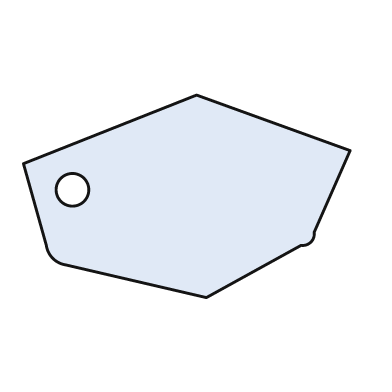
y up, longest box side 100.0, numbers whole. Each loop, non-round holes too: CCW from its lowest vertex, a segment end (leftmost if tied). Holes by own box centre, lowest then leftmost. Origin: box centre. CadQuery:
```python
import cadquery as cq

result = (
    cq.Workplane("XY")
    .moveTo(6.0, -31.0)
    .lineTo(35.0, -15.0)
    .threePointArc((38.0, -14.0), (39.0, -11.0))
    .lineTo(50.0, 14.0)
    .lineTo(3.0, 31.0)
    .lineTo(-50.0, 10.0)
    .lineTo(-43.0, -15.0)
    .threePointArc((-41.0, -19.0), (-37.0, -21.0))
    .close()
    .moveTo(-35.0, 2.0)
    .circle(5.0)
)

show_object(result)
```